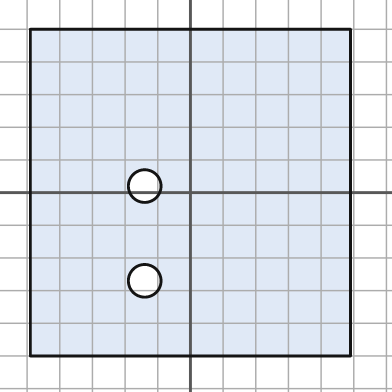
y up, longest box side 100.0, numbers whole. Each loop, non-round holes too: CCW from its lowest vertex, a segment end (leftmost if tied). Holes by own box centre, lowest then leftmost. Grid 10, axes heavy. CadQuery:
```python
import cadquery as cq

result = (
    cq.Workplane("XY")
    .moveTo(-49.0, -50.0)
    .lineTo(49.0, -50.0)
    .lineTo(49.0, 50.0)
    .lineTo(-49.0, 50.0)
    .close()
    .moveTo(-14.0, -27.0)
    .circle(5.0)
    .moveTo(-14.0, 2.0)
    .circle(5.0)
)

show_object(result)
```